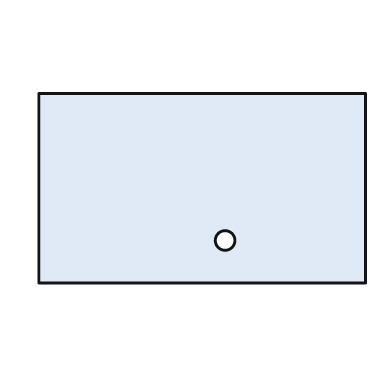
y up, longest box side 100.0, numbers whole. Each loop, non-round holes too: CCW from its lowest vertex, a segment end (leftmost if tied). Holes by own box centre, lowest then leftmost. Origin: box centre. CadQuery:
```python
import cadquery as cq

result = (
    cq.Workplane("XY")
    .moveTo(-50.0, -29.0)
    .lineTo(50.0, -29.0)
    .lineTo(50.0, 29.0)
    .lineTo(-50.0, 29.0)
    .close()
    .moveTo(7.0, -16.0)
    .circle(3.0)
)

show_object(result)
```